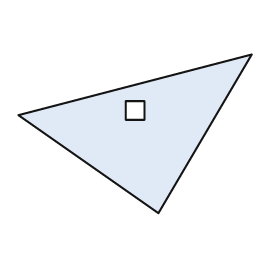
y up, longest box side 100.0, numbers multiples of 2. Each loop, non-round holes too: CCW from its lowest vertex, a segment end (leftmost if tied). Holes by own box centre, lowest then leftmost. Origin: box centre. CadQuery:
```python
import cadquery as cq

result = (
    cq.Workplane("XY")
    .moveTo(10.0, -34.0)
    .lineTo(50.0, 34.0)
    .lineTo(-50.0, 8.0)
    .close()
    .moveTo(-4.0, 6.0)
    .lineTo(4.0, 6.0)
    .lineTo(4.0, 14.0)
    .lineTo(-4.0, 14.0)
    .close()
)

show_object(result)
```